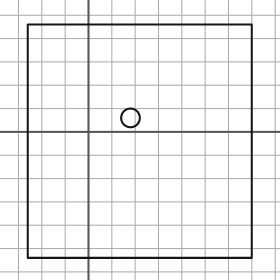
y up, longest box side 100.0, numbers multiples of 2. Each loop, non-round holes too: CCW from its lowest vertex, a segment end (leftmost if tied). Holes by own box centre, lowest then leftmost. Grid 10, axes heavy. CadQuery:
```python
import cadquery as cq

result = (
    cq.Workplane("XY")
    .moveTo(-26.0, -54.0)
    .lineTo(70.0, -54.0)
    .lineTo(70.0, 46.0)
    .lineTo(-26.0, 46.0)
    .close()
    .moveTo(18.0, 6.0)
    .circle(4.0)
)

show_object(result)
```